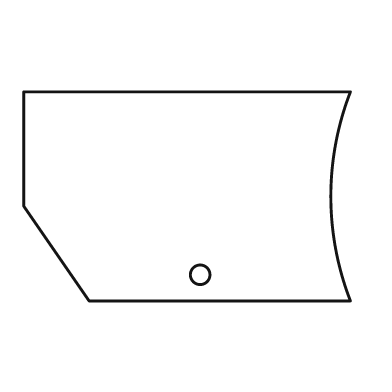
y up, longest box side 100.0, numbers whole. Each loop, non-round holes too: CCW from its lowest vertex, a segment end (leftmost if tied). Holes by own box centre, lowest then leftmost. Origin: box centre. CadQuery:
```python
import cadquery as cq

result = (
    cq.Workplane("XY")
    .moveTo(-30.0, -32.0)
    .lineTo(50.0, -32.0)
    .threePointArc((44.0, 0.0), (50.0, 32.0))
    .lineTo(-50.0, 32.0)
    .lineTo(-50.0, -3.0)
    .close()
    .moveTo(4.0, -24.0)
    .circle(3.0)
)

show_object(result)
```